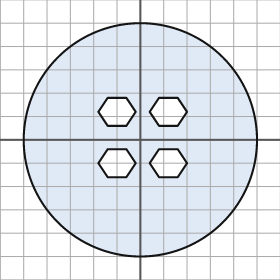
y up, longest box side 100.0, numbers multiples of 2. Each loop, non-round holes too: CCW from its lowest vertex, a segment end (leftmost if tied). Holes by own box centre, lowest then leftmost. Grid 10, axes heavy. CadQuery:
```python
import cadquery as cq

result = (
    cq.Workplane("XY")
    .moveTo(0.0, 0.0)
    .circle(50.0)
    .moveTo(-14.0, -16.0)
    .lineTo(-6.0, -16.0)
    .lineTo(-2.0, -10.0)
    .lineTo(-6.0, -4.0)
    .lineTo(-14.0, -4.0)
    .lineTo(-18.0, -10.0)
    .close()
    .moveTo(8.0, -16.0)
    .lineTo(16.0, -16.0)
    .lineTo(20.0, -10.0)
    .lineTo(16.0, -4.0)
    .lineTo(8.0, -4.0)
    .lineTo(4.0, -10.0)
    .close()
    .moveTo(-14.0, 6.0)
    .lineTo(-6.0, 6.0)
    .lineTo(-2.0, 12.0)
    .lineTo(-6.0, 18.0)
    .lineTo(-14.0, 18.0)
    .lineTo(-18.0, 12.0)
    .close()
    .moveTo(8.0, 6.0)
    .lineTo(16.0, 6.0)
    .lineTo(20.0, 12.0)
    .lineTo(16.0, 18.0)
    .lineTo(8.0, 18.0)
    .lineTo(4.0, 12.0)
    .close()
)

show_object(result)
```